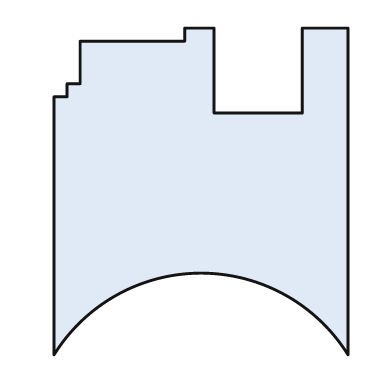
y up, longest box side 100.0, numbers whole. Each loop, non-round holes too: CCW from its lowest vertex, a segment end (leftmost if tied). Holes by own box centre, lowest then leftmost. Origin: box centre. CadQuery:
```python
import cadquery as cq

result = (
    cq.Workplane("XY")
    .moveTo(-45.0, -50.0)
    .threePointArc((0.0, -25.0), (45.0, -50.0))
    .lineTo(45.0, 50.0)
    .lineTo(31.0, 50.0)
    .lineTo(31.0, 24.0)
    .lineTo(4.0, 24.0)
    .lineTo(4.0, 50.0)
    .lineTo(-5.0, 50.0)
    .lineTo(-5.0, 46.0)
    .lineTo(-37.0, 46.0)
    .lineTo(-37.0, 33.0)
    .lineTo(-41.0, 33.0)
    .lineTo(-41.0, 29.0)
    .lineTo(-45.0, 29.0)
    .close()
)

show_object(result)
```